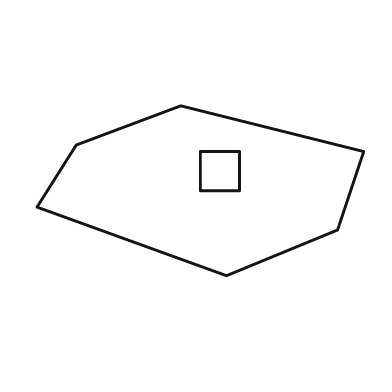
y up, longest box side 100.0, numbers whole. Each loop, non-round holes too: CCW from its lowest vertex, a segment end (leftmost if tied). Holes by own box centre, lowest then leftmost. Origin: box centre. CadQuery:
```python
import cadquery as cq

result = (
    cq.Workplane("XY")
    .moveTo(8.0, -26.0)
    .lineTo(42.0, -12.0)
    .lineTo(50.0, 12.0)
    .lineTo(-6.0, 26.0)
    .lineTo(-38.0, 14.0)
    .lineTo(-50.0, -5.0)
    .close()
    .moveTo(0.0, 0.0)
    .lineTo(12.0, 0.0)
    .lineTo(12.0, 12.0)
    .lineTo(0.0, 12.0)
    .close()
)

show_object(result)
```